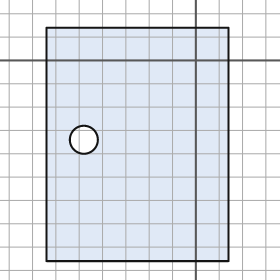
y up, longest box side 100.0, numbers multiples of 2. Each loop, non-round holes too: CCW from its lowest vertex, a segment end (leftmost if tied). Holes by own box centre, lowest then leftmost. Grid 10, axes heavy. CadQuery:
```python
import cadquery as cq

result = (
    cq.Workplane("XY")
    .moveTo(-64.0, -86.0)
    .lineTo(14.0, -86.0)
    .lineTo(14.0, 14.0)
    .lineTo(-64.0, 14.0)
    .close()
    .moveTo(-48.0, -34.0)
    .circle(6.0)
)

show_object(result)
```